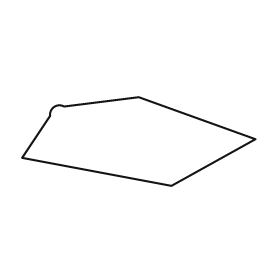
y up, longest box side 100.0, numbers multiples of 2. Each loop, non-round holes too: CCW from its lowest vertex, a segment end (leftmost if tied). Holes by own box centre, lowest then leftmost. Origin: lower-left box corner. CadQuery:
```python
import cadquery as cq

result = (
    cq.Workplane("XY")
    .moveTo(64.0, 0.0)
    .lineTo(100.0, 20.0)
    .lineTo(50.0, 38.0)
    .lineTo(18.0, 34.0)
    .threePointArc((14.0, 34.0), (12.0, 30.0))
    .lineTo(0.0, 12.0)
    .close()
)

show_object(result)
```